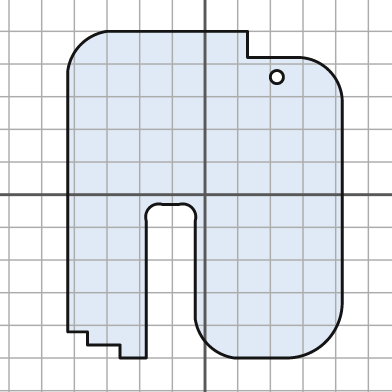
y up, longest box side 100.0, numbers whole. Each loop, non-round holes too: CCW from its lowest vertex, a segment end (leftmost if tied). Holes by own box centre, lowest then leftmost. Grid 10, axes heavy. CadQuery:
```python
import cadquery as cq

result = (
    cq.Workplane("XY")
    .moveTo(-26.0, -50.0)
    .lineTo(-18.0, -50.0)
    .lineTo(-18.0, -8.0)
    .threePointArc((-17.0, -4.0), (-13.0, -3.0))
    .lineTo(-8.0, -3.0)
    .threePointArc((-4.0, -4.0), (-3.0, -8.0))
    .lineTo(-3.0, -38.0)
    .threePointArc((1.0, -46.0), (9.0, -50.0))
    .lineTo(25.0, -50.0)
    .threePointArc((37.0, -45.0), (42.0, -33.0))
    .lineTo(42.0, 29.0)
    .threePointArc((38.0, 38.0), (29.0, 42.0))
    .lineTo(13.0, 42.0)
    .lineTo(13.0, 50.0)
    .lineTo(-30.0, 50.0)
    .threePointArc((-38.0, 46.0), (-42.0, 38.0))
    .lineTo(-42.0, -42.0)
    .lineTo(-36.0, -42.0)
    .lineTo(-36.0, -46.0)
    .lineTo(-26.0, -46.0)
    .close()
    .moveTo(22.0, 36.0)
    .circle(2.0)
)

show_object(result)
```